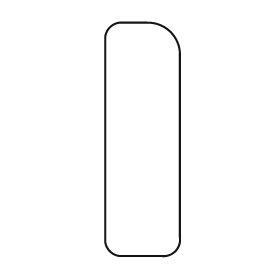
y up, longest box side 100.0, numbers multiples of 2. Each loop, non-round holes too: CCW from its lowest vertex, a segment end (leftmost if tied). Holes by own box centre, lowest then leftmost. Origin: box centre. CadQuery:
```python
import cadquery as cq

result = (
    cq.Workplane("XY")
    .moveTo(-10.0, -50.0)
    .lineTo(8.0, -50.0)
    .threePointArc((14.0, -48.0), (16.0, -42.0))
    .lineTo(16.0, 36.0)
    .threePointArc((12.0, 46.0), (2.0, 50.0))
    .lineTo(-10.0, 50.0)
    .threePointArc((-14.0, 48.0), (-16.0, 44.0))
    .lineTo(-16.0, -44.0)
    .threePointArc((-14.0, -48.0), (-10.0, -50.0))
    .close()
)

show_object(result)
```